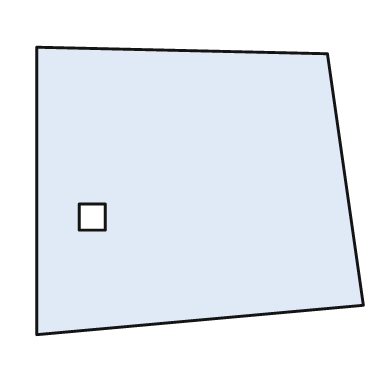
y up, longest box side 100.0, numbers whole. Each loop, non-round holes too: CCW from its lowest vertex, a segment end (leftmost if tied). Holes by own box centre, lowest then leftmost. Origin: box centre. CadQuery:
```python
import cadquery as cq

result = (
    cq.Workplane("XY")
    .moveTo(-50.0, -44.0)
    .lineTo(50.0, -35.0)
    .lineTo(39.0, 42.0)
    .lineTo(-50.0, 44.0)
    .close()
    .moveTo(-37.0, -12.0)
    .lineTo(-29.0, -12.0)
    .lineTo(-29.0, -4.0)
    .lineTo(-37.0, -4.0)
    .close()
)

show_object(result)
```